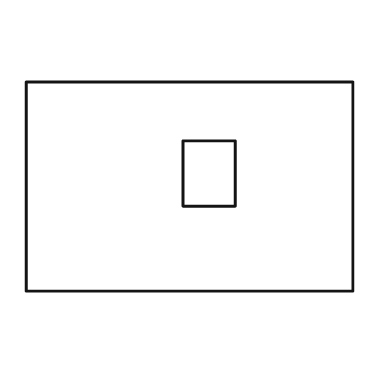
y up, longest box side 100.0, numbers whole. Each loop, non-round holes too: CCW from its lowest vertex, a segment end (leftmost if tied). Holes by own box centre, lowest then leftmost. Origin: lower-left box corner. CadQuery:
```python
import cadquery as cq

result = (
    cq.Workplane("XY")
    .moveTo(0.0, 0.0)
    .lineTo(100.0, 0.0)
    .lineTo(100.0, 64.0)
    .lineTo(0.0, 64.0)
    .close()
    .moveTo(48.0, 26.0)
    .lineTo(64.0, 26.0)
    .lineTo(64.0, 46.0)
    .lineTo(48.0, 46.0)
    .close()
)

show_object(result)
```